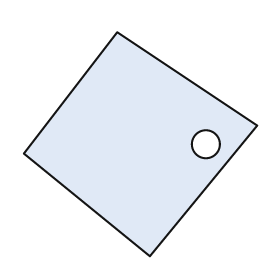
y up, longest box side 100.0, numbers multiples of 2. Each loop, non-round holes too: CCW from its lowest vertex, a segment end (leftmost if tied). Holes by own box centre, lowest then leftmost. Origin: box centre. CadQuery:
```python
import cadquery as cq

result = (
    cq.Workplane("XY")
    .moveTo(4.0, -48.0)
    .lineTo(50.0, 8.0)
    .lineTo(-10.0, 48.0)
    .lineTo(-50.0, -4.0)
    .close()
    .moveTo(28.0, 0.0)
    .circle(6.0)
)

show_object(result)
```